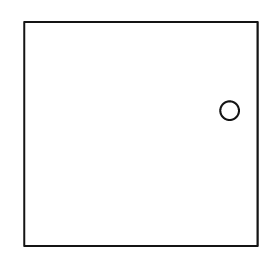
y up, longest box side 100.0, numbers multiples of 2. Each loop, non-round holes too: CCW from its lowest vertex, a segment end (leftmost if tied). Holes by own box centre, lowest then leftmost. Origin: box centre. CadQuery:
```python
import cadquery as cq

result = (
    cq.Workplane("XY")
    .moveTo(-50.0, -48.0)
    .lineTo(50.0, -48.0)
    .lineTo(50.0, 48.0)
    .lineTo(-50.0, 48.0)
    .close()
    .moveTo(38.0, 10.0)
    .circle(4.0)
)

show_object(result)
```